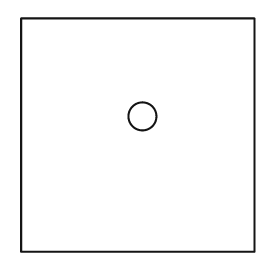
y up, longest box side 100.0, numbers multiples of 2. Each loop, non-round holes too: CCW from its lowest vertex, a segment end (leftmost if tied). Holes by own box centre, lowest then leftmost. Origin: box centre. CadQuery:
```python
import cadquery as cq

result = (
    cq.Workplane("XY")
    .moveTo(-50.0, -50.0)
    .lineTo(50.0, -50.0)
    .lineTo(50.0, 50.0)
    .lineTo(-50.0, 50.0)
    .close()
    .moveTo(2.0, 8.0)
    .circle(6.0)
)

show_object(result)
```